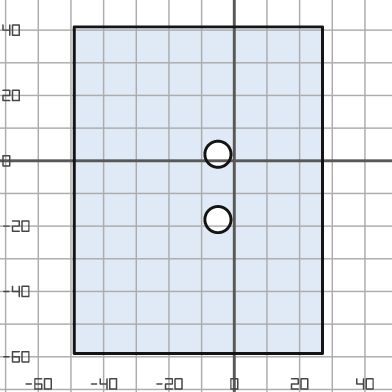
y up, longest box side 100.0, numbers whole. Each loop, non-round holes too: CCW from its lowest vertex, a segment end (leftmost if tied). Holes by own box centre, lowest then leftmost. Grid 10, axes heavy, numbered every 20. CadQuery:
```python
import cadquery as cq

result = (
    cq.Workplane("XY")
    .moveTo(-49.0, -59.0)
    .lineTo(27.0, -59.0)
    .lineTo(27.0, 41.0)
    .lineTo(-49.0, 41.0)
    .close()
    .moveTo(-5.0, -18.0)
    .circle(4.0)
    .moveTo(-5.0, 2.0)
    .circle(4.0)
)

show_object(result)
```